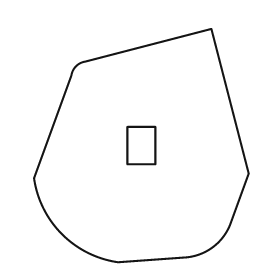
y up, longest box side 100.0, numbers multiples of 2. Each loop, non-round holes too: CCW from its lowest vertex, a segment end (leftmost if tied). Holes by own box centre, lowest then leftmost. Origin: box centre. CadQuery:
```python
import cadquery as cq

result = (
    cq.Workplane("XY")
    .moveTo(-10.0, -50.0)
    .lineTo(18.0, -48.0)
    .threePointArc((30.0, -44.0), (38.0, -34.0))
    .lineTo(46.0, -12.0)
    .lineTo(30.0, 50.0)
    .lineTo(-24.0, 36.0)
    .threePointArc((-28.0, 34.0), (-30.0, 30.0))
    .lineTo(-46.0, -14.0)
    .threePointArc((-34.0, -38.0), (-10.0, -50.0))
    .close()
    .moveTo(-6.0, -8.0)
    .lineTo(6.0, -8.0)
    .lineTo(6.0, 8.0)
    .lineTo(-6.0, 8.0)
    .close()
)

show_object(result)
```